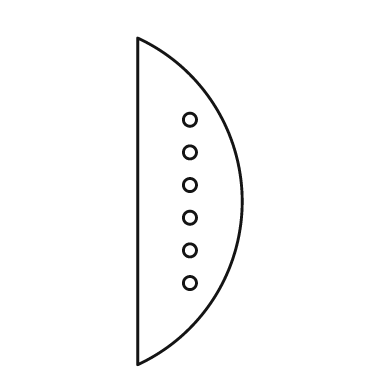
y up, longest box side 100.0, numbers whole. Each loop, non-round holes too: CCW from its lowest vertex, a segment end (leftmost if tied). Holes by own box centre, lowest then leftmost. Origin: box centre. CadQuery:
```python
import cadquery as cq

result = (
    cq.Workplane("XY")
    .moveTo(-16.0, -50.0)
    .threePointArc((16.0, 0.0), (-16.0, 50.0))
    .close()
    .moveTo(0.0, -25.0)
    .circle(2.0)
    .moveTo(0.0, -15.0)
    .circle(2.0)
    .moveTo(0.0, -5.0)
    .circle(2.0)
    .moveTo(0.0, 5.0)
    .circle(2.0)
    .moveTo(0.0, 15.0)
    .circle(2.0)
    .moveTo(0.0, 25.0)
    .circle(2.0)
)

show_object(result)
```